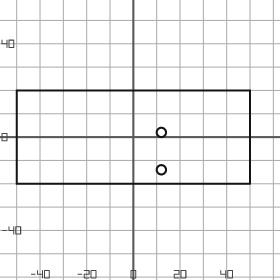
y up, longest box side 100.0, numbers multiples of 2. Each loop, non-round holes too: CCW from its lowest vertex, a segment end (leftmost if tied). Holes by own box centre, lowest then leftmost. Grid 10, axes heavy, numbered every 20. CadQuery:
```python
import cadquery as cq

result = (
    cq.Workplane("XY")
    .moveTo(-50.0, -20.0)
    .lineTo(50.0, -20.0)
    .lineTo(50.0, 20.0)
    .lineTo(-50.0, 20.0)
    .close()
    .moveTo(12.0, -14.0)
    .circle(2.0)
    .moveTo(12.0, 2.0)
    .circle(2.0)
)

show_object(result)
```